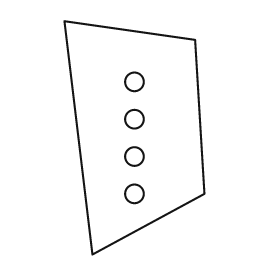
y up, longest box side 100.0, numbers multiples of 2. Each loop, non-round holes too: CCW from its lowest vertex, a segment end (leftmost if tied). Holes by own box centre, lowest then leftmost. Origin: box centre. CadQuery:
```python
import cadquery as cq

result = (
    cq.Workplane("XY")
    .moveTo(-18.0, -50.0)
    .lineTo(30.0, -24.0)
    .lineTo(26.0, 42.0)
    .lineTo(-30.0, 50.0)
    .close()
    .moveTo(0.0, -24.0)
    .circle(4.0)
    .moveTo(0.0, -8.0)
    .circle(4.0)
    .moveTo(0.0, 8.0)
    .circle(4.0)
    .moveTo(0.0, 24.0)
    .circle(4.0)
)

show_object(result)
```